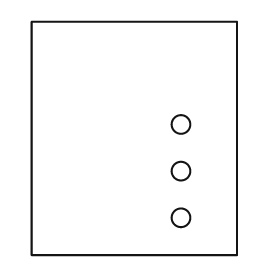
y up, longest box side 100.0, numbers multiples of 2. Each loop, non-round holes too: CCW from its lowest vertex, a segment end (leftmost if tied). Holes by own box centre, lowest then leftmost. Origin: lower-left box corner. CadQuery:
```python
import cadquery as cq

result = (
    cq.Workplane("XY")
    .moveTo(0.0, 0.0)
    .lineTo(88.0, 0.0)
    .lineTo(88.0, 100.0)
    .lineTo(0.0, 100.0)
    .close()
    .moveTo(64.0, 16.0)
    .circle(4.0)
    .moveTo(64.0, 36.0)
    .circle(4.0)
    .moveTo(64.0, 56.0)
    .circle(4.0)
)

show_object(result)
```